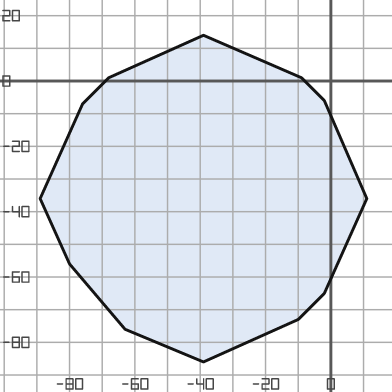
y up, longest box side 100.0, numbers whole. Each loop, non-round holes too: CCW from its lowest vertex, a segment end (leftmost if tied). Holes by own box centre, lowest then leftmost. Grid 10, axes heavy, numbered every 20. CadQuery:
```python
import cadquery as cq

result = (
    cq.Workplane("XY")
    .moveTo(-39.0, -86.0)
    .lineTo(-10.0, -73.0)
    .lineTo(-2.0, -65.0)
    .lineTo(11.0, -36.0)
    .lineTo(-2.0, -6.0)
    .lineTo(-9.0, 1.0)
    .lineTo(-39.0, 14.0)
    .lineTo(-68.0, 1.0)
    .lineTo(-76.0, -7.0)
    .lineTo(-89.0, -36.0)
    .lineTo(-80.0, -56.0)
    .lineTo(-63.0, -76.0)
    .close()
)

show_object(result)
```